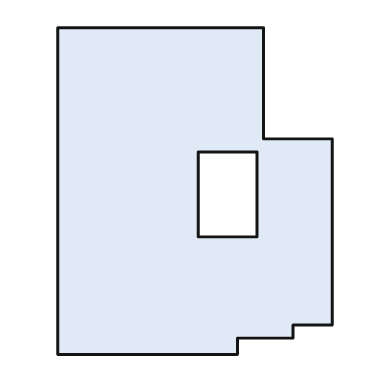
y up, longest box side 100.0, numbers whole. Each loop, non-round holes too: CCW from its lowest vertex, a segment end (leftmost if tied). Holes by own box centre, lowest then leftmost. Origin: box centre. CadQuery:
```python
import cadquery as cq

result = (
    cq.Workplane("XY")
    .moveTo(-42.0, -50.0)
    .lineTo(13.0, -50.0)
    .lineTo(13.0, -45.0)
    .lineTo(30.0, -45.0)
    .lineTo(30.0, -41.0)
    .lineTo(42.0, -41.0)
    .lineTo(42.0, 16.0)
    .lineTo(21.0, 16.0)
    .lineTo(21.0, 50.0)
    .lineTo(-42.0, 50.0)
    .close()
    .moveTo(1.0, -14.0)
    .lineTo(19.0, -14.0)
    .lineTo(19.0, 12.0)
    .lineTo(1.0, 12.0)
    .close()
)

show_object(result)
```